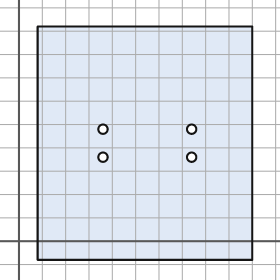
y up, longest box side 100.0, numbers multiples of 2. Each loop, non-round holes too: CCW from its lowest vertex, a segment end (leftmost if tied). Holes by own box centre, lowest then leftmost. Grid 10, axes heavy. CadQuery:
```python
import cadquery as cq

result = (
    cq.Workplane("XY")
    .moveTo(8.0, -8.0)
    .lineTo(100.0, -8.0)
    .lineTo(100.0, 92.0)
    .lineTo(8.0, 92.0)
    .close()
    .moveTo(36.0, 36.0)
    .circle(2.0)
    .moveTo(74.0, 36.0)
    .circle(2.0)
    .moveTo(36.0, 48.0)
    .circle(2.0)
    .moveTo(74.0, 48.0)
    .circle(2.0)
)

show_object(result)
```